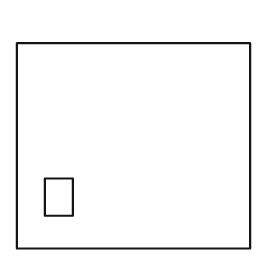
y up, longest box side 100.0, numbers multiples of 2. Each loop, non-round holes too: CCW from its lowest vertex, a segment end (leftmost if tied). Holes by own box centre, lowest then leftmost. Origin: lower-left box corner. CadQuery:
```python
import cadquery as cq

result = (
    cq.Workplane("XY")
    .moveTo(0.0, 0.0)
    .lineTo(100.0, 0.0)
    .lineTo(100.0, 88.0)
    .lineTo(0.0, 88.0)
    .close()
    .moveTo(12.0, 14.0)
    .lineTo(24.0, 14.0)
    .lineTo(24.0, 30.0)
    .lineTo(12.0, 30.0)
    .close()
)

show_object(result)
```